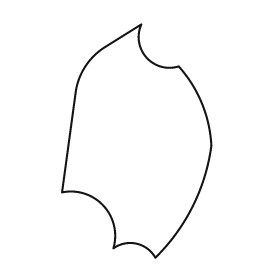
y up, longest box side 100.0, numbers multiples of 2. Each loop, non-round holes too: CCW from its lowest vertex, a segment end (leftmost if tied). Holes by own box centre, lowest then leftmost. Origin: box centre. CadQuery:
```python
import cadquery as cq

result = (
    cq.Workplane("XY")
    .moveTo(8.0, -50.0)
    .threePointArc((24.0, -28.0), (32.0, -2.0))
    .threePointArc((28.0, 16.0), (18.0, 32.0))
    .threePointArc((4.0, 36.0), (2.0, 50.0))
    .lineTo(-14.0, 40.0)
    .threePointArc((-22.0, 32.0), (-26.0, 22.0))
    .lineTo(-32.0, -22.0)
    .threePointArc((-14.0, -28.0), (-10.0, -46.0))
    .threePointArc((0.0, -44.0), (8.0, -50.0))
    .close()
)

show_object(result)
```